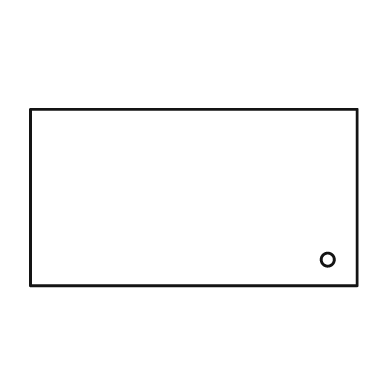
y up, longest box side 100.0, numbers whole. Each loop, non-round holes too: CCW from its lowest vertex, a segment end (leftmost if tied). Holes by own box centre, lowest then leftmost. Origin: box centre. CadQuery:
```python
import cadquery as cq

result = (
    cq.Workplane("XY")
    .moveTo(-50.0, -27.0)
    .lineTo(50.0, -27.0)
    .lineTo(50.0, 27.0)
    .lineTo(-50.0, 27.0)
    .close()
    .moveTo(41.0, -19.0)
    .circle(2.0)
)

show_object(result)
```